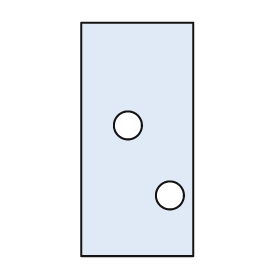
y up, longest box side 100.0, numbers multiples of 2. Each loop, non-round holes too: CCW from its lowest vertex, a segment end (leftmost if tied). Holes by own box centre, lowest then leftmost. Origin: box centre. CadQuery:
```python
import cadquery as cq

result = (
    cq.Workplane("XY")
    .moveTo(-24.0, -50.0)
    .lineTo(24.0, -50.0)
    .lineTo(24.0, 50.0)
    .lineTo(-24.0, 50.0)
    .close()
    .moveTo(14.0, -24.0)
    .circle(6.0)
    .moveTo(-4.0, 6.0)
    .circle(6.0)
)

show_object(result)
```